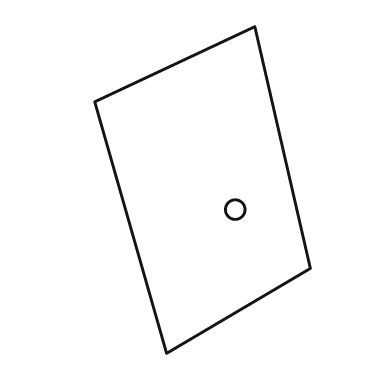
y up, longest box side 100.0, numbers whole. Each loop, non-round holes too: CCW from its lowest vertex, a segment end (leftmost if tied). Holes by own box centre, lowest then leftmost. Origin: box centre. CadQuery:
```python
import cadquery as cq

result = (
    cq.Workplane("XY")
    .moveTo(-11.0, -50.0)
    .lineTo(33.0, -24.0)
    .lineTo(16.0, 50.0)
    .lineTo(-33.0, 27.0)
    .close()
    .moveTo(10.0, -6.0)
    .circle(3.0)
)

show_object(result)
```